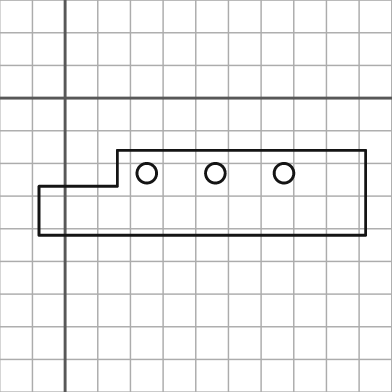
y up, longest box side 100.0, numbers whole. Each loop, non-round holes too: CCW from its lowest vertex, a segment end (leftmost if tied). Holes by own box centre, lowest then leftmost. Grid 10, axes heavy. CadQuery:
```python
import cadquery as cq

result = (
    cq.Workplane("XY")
    .moveTo(-8.0, -42.0)
    .lineTo(92.0, -42.0)
    .lineTo(92.0, -16.0)
    .lineTo(16.0, -16.0)
    .lineTo(16.0, -27.0)
    .lineTo(-8.0, -27.0)
    .close()
    .moveTo(25.0, -23.0)
    .circle(3.0)
    .moveTo(46.0, -23.0)
    .circle(3.0)
    .moveTo(67.0, -23.0)
    .circle(3.0)
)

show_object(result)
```